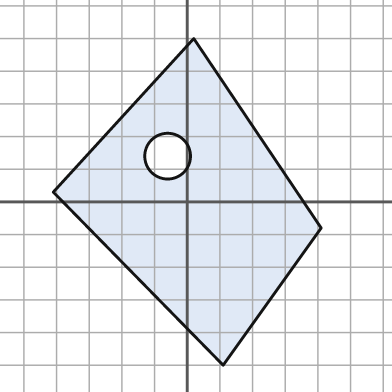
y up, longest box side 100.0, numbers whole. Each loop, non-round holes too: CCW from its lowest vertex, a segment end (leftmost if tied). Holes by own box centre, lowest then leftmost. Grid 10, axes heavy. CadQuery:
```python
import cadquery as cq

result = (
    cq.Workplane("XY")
    .moveTo(11.0, -50.0)
    .lineTo(41.0, -8.0)
    .lineTo(2.0, 50.0)
    .lineTo(-41.0, 3.0)
    .close()
    .moveTo(-6.0, 14.0)
    .circle(7.0)
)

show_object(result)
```